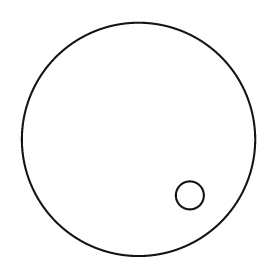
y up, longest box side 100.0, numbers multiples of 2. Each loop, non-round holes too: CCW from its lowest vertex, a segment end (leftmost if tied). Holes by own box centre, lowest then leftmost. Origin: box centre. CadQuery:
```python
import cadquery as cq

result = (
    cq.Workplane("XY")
    .moveTo(0.0, 0.0)
    .circle(50.0)
    .moveTo(22.0, -24.0)
    .circle(6.0)
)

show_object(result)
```